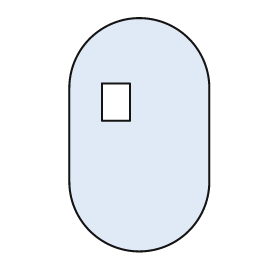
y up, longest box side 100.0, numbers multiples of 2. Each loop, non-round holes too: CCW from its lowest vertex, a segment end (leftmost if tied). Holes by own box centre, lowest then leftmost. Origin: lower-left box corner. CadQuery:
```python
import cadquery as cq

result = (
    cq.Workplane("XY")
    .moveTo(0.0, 30.0)
    .threePointArc((30.0, 0.0), (60.0, 30.0))
    .lineTo(60.0, 70.0)
    .threePointArc((30.0, 100.0), (0.0, 70.0))
    .close()
    .moveTo(14.0, 56.0)
    .lineTo(26.0, 56.0)
    .lineTo(26.0, 72.0)
    .lineTo(14.0, 72.0)
    .close()
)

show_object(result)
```